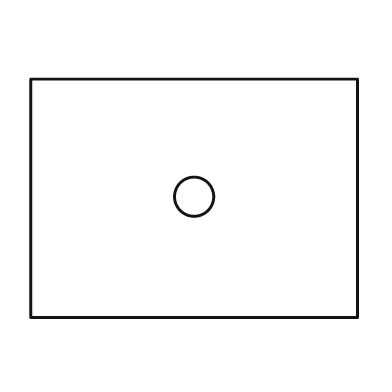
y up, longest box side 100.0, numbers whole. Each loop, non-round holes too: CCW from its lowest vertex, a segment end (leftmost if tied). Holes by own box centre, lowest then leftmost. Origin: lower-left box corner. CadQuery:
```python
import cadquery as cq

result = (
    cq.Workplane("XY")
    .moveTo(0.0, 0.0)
    .lineTo(100.0, 0.0)
    .lineTo(100.0, 73.0)
    .lineTo(0.0, 73.0)
    .close()
    .moveTo(50.0, 37.0)
    .circle(6.0)
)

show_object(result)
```